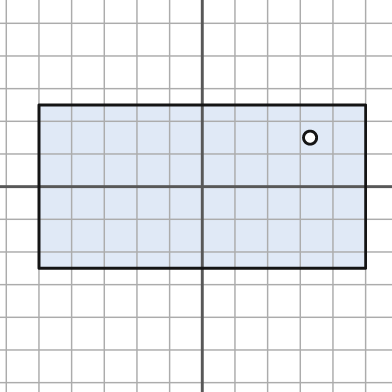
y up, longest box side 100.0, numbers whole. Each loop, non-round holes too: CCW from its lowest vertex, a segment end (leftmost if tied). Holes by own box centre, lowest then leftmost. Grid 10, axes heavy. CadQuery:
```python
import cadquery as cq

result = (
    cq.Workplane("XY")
    .moveTo(-50.0, -25.0)
    .lineTo(50.0, -25.0)
    .lineTo(50.0, 25.0)
    .lineTo(-50.0, 25.0)
    .close()
    .moveTo(33.0, 15.0)
    .circle(2.0)
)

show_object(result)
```